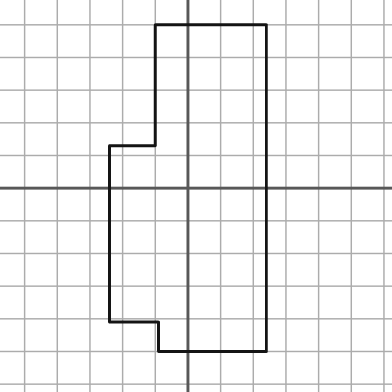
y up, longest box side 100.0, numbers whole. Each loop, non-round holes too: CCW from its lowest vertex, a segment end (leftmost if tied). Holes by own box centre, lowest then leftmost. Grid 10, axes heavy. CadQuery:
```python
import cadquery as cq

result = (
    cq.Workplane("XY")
    .moveTo(-9.0, -50.0)
    .lineTo(24.0, -50.0)
    .lineTo(24.0, 50.0)
    .lineTo(-10.0, 50.0)
    .lineTo(-10.0, 13.0)
    .lineTo(-24.0, 13.0)
    .lineTo(-24.0, -41.0)
    .lineTo(-9.0, -41.0)
    .close()
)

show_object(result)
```